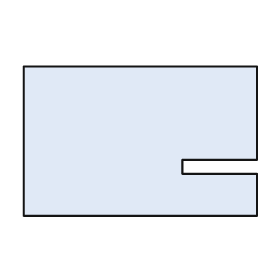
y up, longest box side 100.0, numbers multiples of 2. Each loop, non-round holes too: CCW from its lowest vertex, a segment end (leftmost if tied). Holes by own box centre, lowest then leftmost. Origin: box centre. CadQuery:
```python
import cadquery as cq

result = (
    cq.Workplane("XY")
    .moveTo(-50.0, -32.0)
    .lineTo(50.0, -32.0)
    .lineTo(50.0, -14.0)
    .lineTo(18.0, -14.0)
    .lineTo(18.0, -8.0)
    .lineTo(50.0, -8.0)
    .lineTo(50.0, 32.0)
    .lineTo(-50.0, 32.0)
    .close()
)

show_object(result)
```